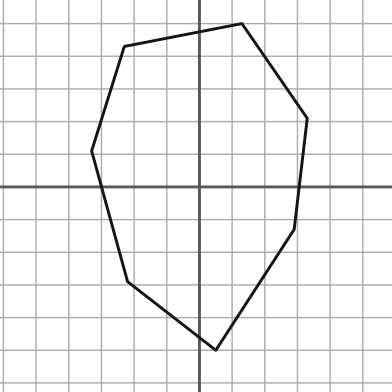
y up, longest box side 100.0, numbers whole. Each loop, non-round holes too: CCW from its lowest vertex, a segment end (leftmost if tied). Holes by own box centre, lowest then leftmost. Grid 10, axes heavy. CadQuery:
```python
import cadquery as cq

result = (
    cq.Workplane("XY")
    .moveTo(5.0, -50.0)
    .lineTo(29.0, -13.0)
    .lineTo(33.0, 21.0)
    .lineTo(13.0, 50.0)
    .lineTo(-23.0, 43.0)
    .lineTo(-33.0, 11.0)
    .lineTo(-22.0, -29.0)
    .close()
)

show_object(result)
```